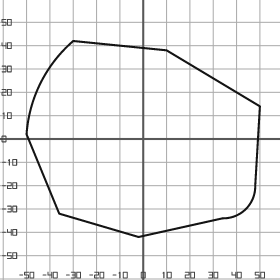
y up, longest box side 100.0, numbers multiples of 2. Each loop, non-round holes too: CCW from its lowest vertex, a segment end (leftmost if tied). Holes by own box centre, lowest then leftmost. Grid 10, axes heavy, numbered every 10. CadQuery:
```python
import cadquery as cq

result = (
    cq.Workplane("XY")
    .moveTo(-2.0, -42.0)
    .lineTo(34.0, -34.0)
    .threePointArc((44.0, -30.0), (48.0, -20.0))
    .lineTo(50.0, 14.0)
    .lineTo(10.0, 38.0)
    .lineTo(-30.0, 42.0)
    .threePointArc((-44.0, 24.0), (-50.0, 2.0))
    .lineTo(-36.0, -32.0)
    .close()
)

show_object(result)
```